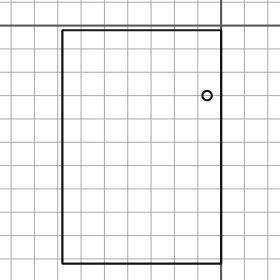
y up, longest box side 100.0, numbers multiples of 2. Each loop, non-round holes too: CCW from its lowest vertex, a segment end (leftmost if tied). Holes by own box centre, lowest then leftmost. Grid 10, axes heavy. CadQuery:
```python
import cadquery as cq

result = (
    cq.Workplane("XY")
    .moveTo(-68.0, -102.0)
    .lineTo(0.0, -102.0)
    .lineTo(0.0, -2.0)
    .lineTo(-68.0, -2.0)
    .close()
    .moveTo(-6.0, -30.0)
    .circle(2.0)
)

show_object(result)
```